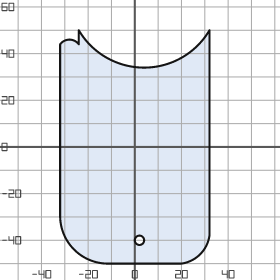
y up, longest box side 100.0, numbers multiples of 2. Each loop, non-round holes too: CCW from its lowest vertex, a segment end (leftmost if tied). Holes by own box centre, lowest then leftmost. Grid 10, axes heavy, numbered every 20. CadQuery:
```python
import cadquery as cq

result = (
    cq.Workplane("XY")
    .moveTo(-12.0, -50.0)
    .lineTo(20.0, -50.0)
    .threePointArc((28.0, -46.0), (32.0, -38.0))
    .lineTo(32.0, 50.0)
    .threePointArc((4.0, 34.0), (-24.0, 50.0))
    .lineTo(-24.0, 44.0)
    .threePointArc((-28.0, 46.0), (-32.0, 44.0))
    .lineTo(-32.0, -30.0)
    .threePointArc((-26.0, -44.0), (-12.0, -50.0))
    .close()
    .moveTo(2.0, -40.0)
    .circle(2.0)
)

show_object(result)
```